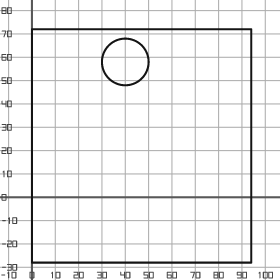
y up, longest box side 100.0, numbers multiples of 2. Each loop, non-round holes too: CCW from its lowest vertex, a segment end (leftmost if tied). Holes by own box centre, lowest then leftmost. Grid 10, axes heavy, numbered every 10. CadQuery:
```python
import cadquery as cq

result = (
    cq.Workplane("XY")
    .moveTo(0.0, -28.0)
    .lineTo(94.0, -28.0)
    .lineTo(94.0, 72.0)
    .lineTo(0.0, 72.0)
    .close()
    .moveTo(40.0, 58.0)
    .circle(10.0)
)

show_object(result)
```